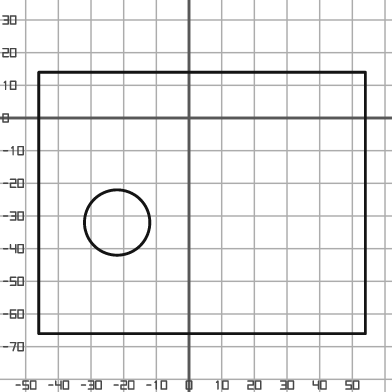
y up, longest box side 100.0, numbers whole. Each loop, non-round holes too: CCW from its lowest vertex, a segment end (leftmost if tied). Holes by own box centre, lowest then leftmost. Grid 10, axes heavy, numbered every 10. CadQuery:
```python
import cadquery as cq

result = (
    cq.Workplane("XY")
    .moveTo(-46.0, -66.0)
    .lineTo(54.0, -66.0)
    .lineTo(54.0, 14.0)
    .lineTo(-46.0, 14.0)
    .close()
    .moveTo(-22.0, -32.0)
    .circle(10.0)
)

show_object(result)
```